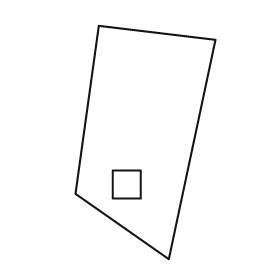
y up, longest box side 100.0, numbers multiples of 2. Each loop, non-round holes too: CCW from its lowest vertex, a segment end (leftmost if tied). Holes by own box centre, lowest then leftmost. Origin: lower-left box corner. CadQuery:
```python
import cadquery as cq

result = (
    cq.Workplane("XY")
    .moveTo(40.0, 0.0)
    .lineTo(60.0, 94.0)
    .lineTo(10.0, 100.0)
    .lineTo(0.0, 28.0)
    .close()
    .moveTo(16.0, 26.0)
    .lineTo(28.0, 26.0)
    .lineTo(28.0, 38.0)
    .lineTo(16.0, 38.0)
    .close()
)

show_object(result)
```